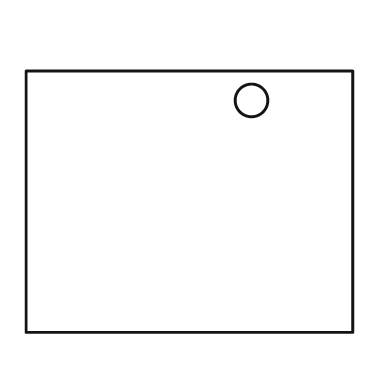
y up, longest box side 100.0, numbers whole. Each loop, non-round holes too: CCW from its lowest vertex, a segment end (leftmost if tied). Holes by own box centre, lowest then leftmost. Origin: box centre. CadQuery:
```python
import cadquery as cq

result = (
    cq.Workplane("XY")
    .moveTo(-50.0, -40.0)
    .lineTo(50.0, -40.0)
    .lineTo(50.0, 40.0)
    .lineTo(-50.0, 40.0)
    .close()
    .moveTo(19.0, 31.0)
    .circle(5.0)
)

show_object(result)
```